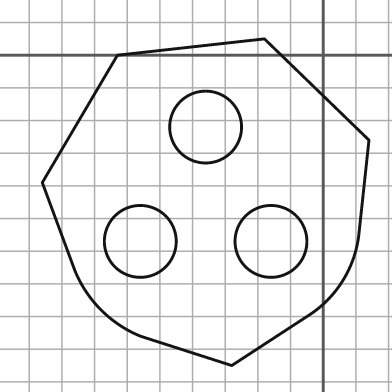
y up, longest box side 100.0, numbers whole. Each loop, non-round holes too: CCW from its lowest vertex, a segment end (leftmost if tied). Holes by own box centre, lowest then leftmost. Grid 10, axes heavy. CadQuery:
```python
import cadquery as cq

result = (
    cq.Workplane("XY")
    .moveTo(-28.0, -95.0)
    .lineTo(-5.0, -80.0)
    .threePointArc((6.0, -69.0), (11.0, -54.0))
    .lineTo(14.0, -26.0)
    .lineTo(-18.0, 5.0)
    .lineTo(-63.0, 0.0)
    .lineTo(-86.0, -39.0)
    .lineTo(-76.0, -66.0)
    .threePointArc((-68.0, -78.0), (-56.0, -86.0))
    .close()
    .moveTo(-56.0, -57.0)
    .circle(11.0)
    .moveTo(-16.0, -57.0)
    .circle(11.0)
    .moveTo(-36.0, -22.0)
    .circle(11.0)
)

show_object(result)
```